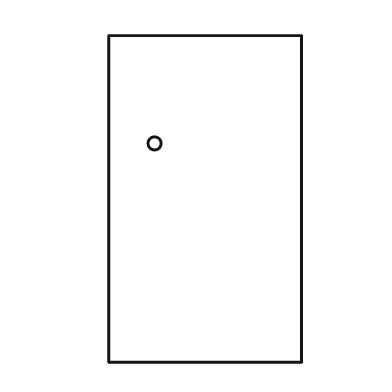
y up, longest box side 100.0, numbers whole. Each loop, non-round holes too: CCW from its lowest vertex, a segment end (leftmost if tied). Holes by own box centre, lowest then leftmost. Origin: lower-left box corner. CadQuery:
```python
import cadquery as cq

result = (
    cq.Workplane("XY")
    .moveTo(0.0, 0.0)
    .lineTo(59.0, 0.0)
    .lineTo(59.0, 100.0)
    .lineTo(0.0, 100.0)
    .close()
    .moveTo(14.0, 67.0)
    .circle(2.0)
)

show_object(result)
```